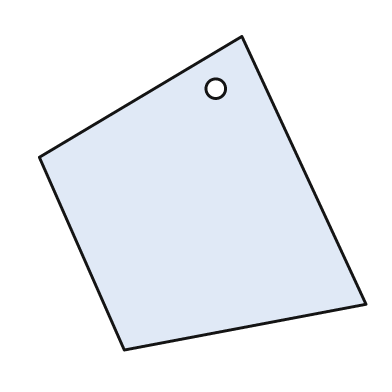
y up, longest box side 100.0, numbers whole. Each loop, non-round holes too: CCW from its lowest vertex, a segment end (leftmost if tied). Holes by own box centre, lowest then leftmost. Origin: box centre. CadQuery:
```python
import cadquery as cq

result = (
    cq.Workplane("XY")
    .moveTo(-24.0, -48.0)
    .lineTo(50.0, -34.0)
    .lineTo(12.0, 48.0)
    .lineTo(-50.0, 11.0)
    .close()
    .moveTo(4.0, 32.0)
    .circle(3.0)
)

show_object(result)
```